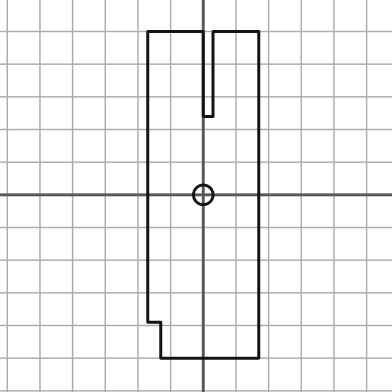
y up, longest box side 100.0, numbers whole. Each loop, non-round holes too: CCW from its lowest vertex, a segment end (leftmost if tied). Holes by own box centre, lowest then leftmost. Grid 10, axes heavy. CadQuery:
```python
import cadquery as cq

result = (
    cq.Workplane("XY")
    .moveTo(-13.0, -50.0)
    .lineTo(17.0, -50.0)
    .lineTo(17.0, 50.0)
    .lineTo(3.0, 50.0)
    .lineTo(3.0, 24.0)
    .lineTo(0.0, 24.0)
    .lineTo(0.0, 50.0)
    .lineTo(-17.0, 50.0)
    .lineTo(-17.0, -39.0)
    .lineTo(-13.0, -39.0)
    .close()
    .moveTo(0.0, 0.0)
    .circle(3.0)
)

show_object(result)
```